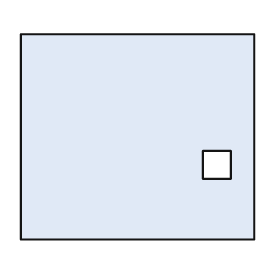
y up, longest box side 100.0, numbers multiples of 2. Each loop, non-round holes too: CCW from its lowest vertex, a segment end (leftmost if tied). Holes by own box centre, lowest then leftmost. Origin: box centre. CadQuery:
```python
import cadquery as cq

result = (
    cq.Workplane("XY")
    .moveTo(-50.0, -44.0)
    .lineTo(50.0, -44.0)
    .lineTo(50.0, 44.0)
    .lineTo(-50.0, 44.0)
    .close()
    .moveTo(28.0, -18.0)
    .lineTo(40.0, -18.0)
    .lineTo(40.0, -6.0)
    .lineTo(28.0, -6.0)
    .close()
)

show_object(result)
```